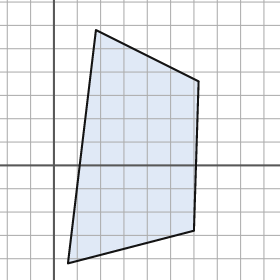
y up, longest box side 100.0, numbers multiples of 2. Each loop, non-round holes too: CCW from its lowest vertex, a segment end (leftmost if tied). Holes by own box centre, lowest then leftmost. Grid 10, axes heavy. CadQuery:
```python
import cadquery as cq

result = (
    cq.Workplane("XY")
    .moveTo(6.0, -42.0)
    .lineTo(60.0, -28.0)
    .lineTo(62.0, 36.0)
    .lineTo(18.0, 58.0)
    .close()
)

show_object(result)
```